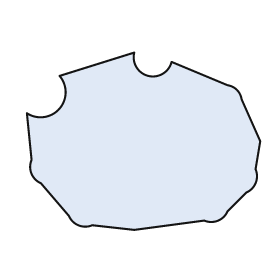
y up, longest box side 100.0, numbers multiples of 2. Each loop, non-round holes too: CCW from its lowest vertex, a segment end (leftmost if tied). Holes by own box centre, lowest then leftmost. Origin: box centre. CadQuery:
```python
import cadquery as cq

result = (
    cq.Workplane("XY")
    .moveTo(-4.0, -38.0)
    .lineTo(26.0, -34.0)
    .threePointArc((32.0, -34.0), (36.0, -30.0))
    .lineTo(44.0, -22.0)
    .threePointArc((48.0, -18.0), (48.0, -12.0))
    .lineTo(50.0, 0.0)
    .lineTo(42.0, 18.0)
    .threePointArc((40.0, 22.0), (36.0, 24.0))
    .lineTo(12.0, 34.0)
    .threePointArc((2.0, 28.0), (-4.0, 38.0))
    .lineTo(-36.0, 28.0)
    .threePointArc((-36.0, 14.0), (-50.0, 12.0))
    .lineTo(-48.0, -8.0)
    .threePointArc((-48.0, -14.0), (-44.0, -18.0))
    .lineTo(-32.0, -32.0)
    .threePointArc((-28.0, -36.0), (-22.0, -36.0))
    .close()
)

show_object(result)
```